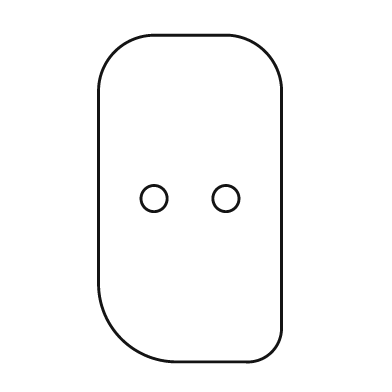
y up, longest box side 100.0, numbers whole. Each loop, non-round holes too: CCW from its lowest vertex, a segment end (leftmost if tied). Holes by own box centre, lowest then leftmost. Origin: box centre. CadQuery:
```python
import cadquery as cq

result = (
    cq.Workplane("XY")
    .moveTo(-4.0, -50.0)
    .lineTo(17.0, -50.0)
    .threePointArc((25.0, -47.0), (28.0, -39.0))
    .lineTo(28.0, 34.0)
    .threePointArc((23.0, 45.0), (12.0, 50.0))
    .lineTo(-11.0, 50.0)
    .threePointArc((-23.0, 45.0), (-28.0, 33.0))
    .lineTo(-28.0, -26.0)
    .threePointArc((-21.0, -43.0), (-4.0, -50.0))
    .close()
    .moveTo(-11.0, 0.0)
    .circle(4.0)
    .moveTo(11.0, 0.0)
    .circle(4.0)
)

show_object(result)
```